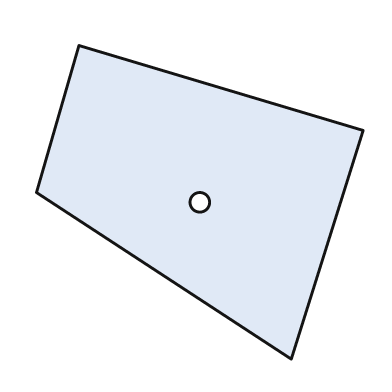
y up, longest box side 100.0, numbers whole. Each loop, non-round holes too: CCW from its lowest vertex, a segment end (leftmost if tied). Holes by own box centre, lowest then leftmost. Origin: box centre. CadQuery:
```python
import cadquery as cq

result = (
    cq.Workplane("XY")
    .moveTo(28.0, -48.0)
    .lineTo(50.0, 22.0)
    .lineTo(-37.0, 48.0)
    .lineTo(-50.0, 3.0)
    .close()
    .moveTo(0.0, 0.0)
    .circle(3.0)
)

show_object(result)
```